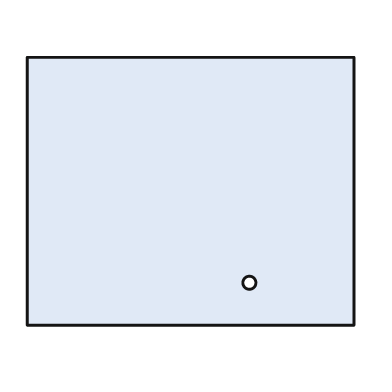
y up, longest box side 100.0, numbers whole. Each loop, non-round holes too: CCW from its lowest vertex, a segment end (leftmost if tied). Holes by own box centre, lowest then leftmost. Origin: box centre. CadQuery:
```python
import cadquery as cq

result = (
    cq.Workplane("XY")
    .moveTo(-50.0, -41.0)
    .lineTo(50.0, -41.0)
    .lineTo(50.0, 41.0)
    .lineTo(-50.0, 41.0)
    .close()
    .moveTo(18.0, -28.0)
    .circle(2.0)
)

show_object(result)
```